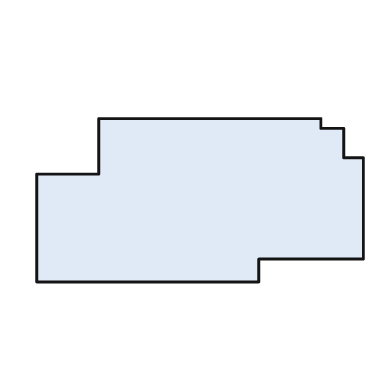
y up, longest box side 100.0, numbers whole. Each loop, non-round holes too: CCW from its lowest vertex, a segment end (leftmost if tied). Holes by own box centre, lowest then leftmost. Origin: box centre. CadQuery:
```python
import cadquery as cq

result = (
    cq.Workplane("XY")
    .moveTo(-50.0, -25.0)
    .lineTo(18.0, -25.0)
    .lineTo(18.0, -18.0)
    .lineTo(50.0, -18.0)
    .lineTo(50.0, 13.0)
    .lineTo(44.0, 13.0)
    .lineTo(44.0, 22.0)
    .lineTo(37.0, 22.0)
    .lineTo(37.0, 25.0)
    .lineTo(-31.0, 25.0)
    .lineTo(-31.0, 8.0)
    .lineTo(-50.0, 8.0)
    .close()
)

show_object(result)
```